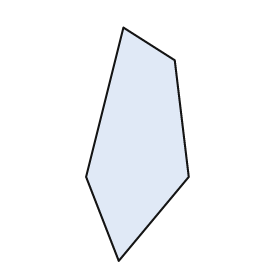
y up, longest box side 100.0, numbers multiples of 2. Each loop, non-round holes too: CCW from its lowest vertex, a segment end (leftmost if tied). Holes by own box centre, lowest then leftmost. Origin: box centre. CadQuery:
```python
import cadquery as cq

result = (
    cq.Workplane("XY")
    .moveTo(-8.0, -50.0)
    .lineTo(22.0, -14.0)
    .lineTo(16.0, 36.0)
    .lineTo(-6.0, 50.0)
    .lineTo(-22.0, -14.0)
    .close()
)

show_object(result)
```